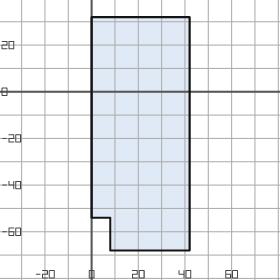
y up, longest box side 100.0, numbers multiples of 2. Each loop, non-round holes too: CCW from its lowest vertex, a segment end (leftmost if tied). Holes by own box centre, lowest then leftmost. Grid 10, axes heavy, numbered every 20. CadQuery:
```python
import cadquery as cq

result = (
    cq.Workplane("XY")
    .moveTo(8.0, -68.0)
    .lineTo(42.0, -68.0)
    .lineTo(42.0, 32.0)
    .lineTo(0.0, 32.0)
    .lineTo(0.0, -54.0)
    .lineTo(8.0, -54.0)
    .close()
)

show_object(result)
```